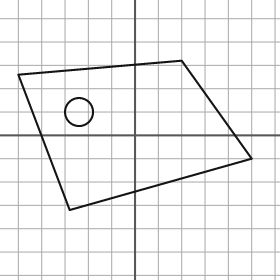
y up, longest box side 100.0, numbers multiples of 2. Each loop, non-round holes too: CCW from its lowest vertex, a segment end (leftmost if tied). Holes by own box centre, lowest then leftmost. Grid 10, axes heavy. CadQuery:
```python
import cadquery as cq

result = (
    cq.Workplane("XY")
    .moveTo(-28.0, -32.0)
    .lineTo(50.0, -10.0)
    .lineTo(20.0, 32.0)
    .lineTo(-50.0, 26.0)
    .close()
    .moveTo(-24.0, 10.0)
    .circle(6.0)
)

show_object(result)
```